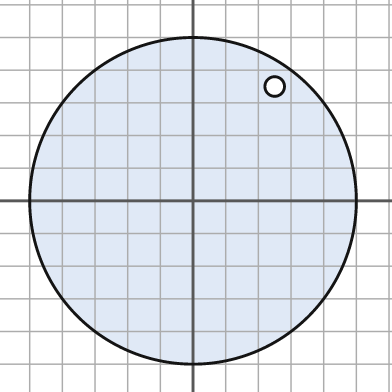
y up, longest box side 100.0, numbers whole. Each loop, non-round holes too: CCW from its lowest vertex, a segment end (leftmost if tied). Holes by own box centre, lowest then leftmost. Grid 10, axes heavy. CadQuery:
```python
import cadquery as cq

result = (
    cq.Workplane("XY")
    .moveTo(0.0, 0.0)
    .circle(50.0)
    .moveTo(25.0, 35.0)
    .circle(3.0)
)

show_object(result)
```